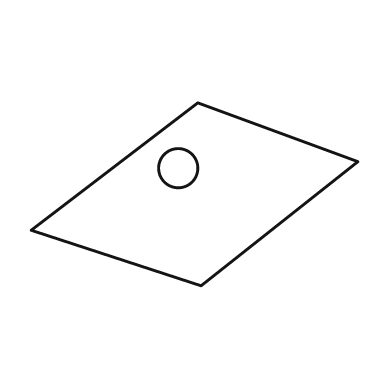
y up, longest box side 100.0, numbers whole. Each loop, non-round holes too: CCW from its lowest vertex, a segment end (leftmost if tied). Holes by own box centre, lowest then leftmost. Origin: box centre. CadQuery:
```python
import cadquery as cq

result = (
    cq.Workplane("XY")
    .moveTo(2.0, -28.0)
    .lineTo(50.0, 10.0)
    .lineTo(1.0, 28.0)
    .lineTo(-50.0, -11.0)
    .close()
    .moveTo(-5.0, 8.0)
    .circle(6.0)
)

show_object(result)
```